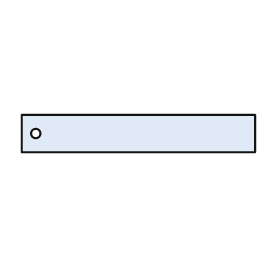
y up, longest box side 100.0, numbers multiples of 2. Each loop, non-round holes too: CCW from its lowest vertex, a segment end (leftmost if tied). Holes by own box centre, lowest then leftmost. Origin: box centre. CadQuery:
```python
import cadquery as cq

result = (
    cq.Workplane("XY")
    .moveTo(-50.0, -8.0)
    .lineTo(50.0, -8.0)
    .lineTo(50.0, 8.0)
    .lineTo(-50.0, 8.0)
    .close()
    .moveTo(-44.0, 0.0)
    .circle(2.0)
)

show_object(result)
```